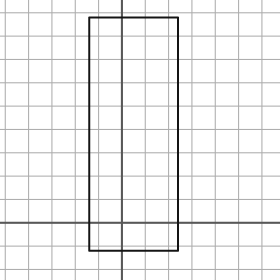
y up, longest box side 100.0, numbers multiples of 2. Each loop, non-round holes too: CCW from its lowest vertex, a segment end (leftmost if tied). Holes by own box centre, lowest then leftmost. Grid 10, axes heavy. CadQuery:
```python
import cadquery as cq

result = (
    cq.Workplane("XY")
    .moveTo(-14.0, -12.0)
    .lineTo(24.0, -12.0)
    .lineTo(24.0, 88.0)
    .lineTo(-14.0, 88.0)
    .close()
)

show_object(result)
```